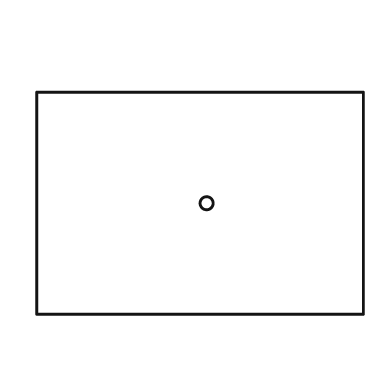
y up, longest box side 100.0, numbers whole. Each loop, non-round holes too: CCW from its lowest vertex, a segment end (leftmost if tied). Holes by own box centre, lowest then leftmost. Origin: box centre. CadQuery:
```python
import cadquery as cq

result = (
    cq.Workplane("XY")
    .moveTo(-50.0, -34.0)
    .lineTo(50.0, -34.0)
    .lineTo(50.0, 34.0)
    .lineTo(-50.0, 34.0)
    .close()
    .moveTo(2.0, 0.0)
    .circle(2.0)
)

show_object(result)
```